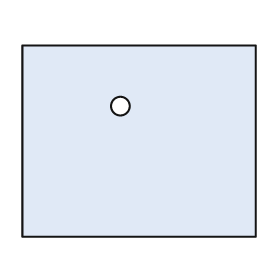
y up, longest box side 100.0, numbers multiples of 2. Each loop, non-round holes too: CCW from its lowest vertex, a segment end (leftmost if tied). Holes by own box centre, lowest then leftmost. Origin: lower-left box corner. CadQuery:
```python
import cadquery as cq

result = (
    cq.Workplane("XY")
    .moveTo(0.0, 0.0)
    .lineTo(100.0, 0.0)
    .lineTo(100.0, 82.0)
    .lineTo(0.0, 82.0)
    .close()
    .moveTo(42.0, 56.0)
    .circle(4.0)
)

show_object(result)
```